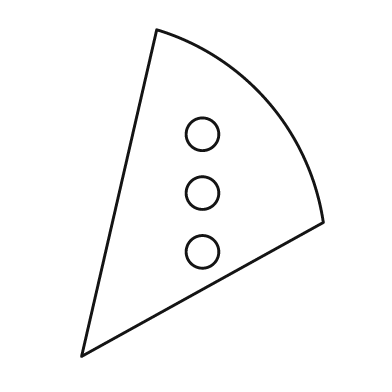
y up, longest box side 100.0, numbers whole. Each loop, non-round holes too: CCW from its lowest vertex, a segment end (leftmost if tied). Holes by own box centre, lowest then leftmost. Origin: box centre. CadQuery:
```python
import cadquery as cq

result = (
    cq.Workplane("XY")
    .moveTo(-37.0, -50.0)
    .lineTo(37.0, -9.0)
    .threePointArc((20.0, 28.0), (-14.0, 50.0))
    .close()
    .moveTo(0.0, -18.0)
    .circle(5.0)
    .moveTo(0.0, 0.0)
    .circle(5.0)
    .moveTo(0.0, 18.0)
    .circle(5.0)
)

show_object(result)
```